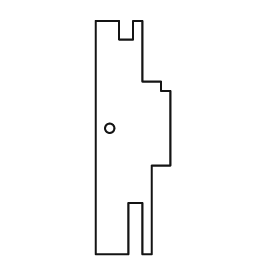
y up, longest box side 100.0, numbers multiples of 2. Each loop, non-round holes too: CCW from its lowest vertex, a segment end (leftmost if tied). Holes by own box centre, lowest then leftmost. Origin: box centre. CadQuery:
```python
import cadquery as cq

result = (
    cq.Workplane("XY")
    .moveTo(-16.0, -50.0)
    .lineTo(-2.0, -50.0)
    .lineTo(-2.0, -28.0)
    .lineTo(4.0, -28.0)
    .lineTo(4.0, -50.0)
    .lineTo(8.0, -50.0)
    .lineTo(8.0, -12.0)
    .lineTo(16.0, -12.0)
    .lineTo(16.0, 20.0)
    .lineTo(12.0, 20.0)
    .lineTo(12.0, 24.0)
    .lineTo(4.0, 24.0)
    .lineTo(4.0, 50.0)
    .lineTo(0.0, 50.0)
    .lineTo(0.0, 42.0)
    .lineTo(-6.0, 42.0)
    .lineTo(-6.0, 50.0)
    .lineTo(-16.0, 50.0)
    .close()
    .moveTo(-10.0, 4.0)
    .circle(2.0)
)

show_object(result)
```